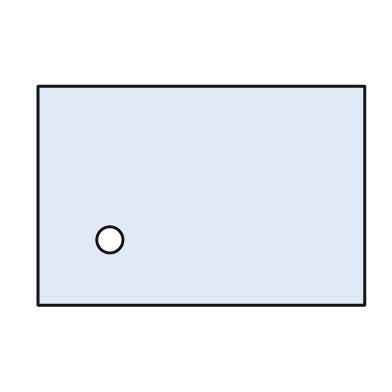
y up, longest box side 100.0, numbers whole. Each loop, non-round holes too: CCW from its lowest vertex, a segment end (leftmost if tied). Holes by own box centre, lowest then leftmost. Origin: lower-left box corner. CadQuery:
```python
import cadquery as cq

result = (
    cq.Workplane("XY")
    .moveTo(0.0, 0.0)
    .lineTo(100.0, 0.0)
    .lineTo(100.0, 67.0)
    .lineTo(0.0, 67.0)
    .close()
    .moveTo(22.0, 20.0)
    .circle(4.0)
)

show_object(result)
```